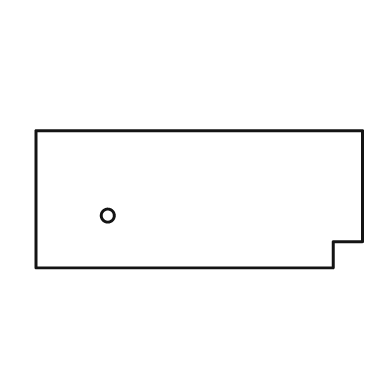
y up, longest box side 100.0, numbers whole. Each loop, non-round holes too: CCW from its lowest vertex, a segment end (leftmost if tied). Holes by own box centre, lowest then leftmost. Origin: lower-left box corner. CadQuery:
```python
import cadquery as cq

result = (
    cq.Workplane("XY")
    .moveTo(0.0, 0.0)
    .lineTo(91.0, 0.0)
    .lineTo(91.0, 8.0)
    .lineTo(100.0, 8.0)
    .lineTo(100.0, 42.0)
    .lineTo(0.0, 42.0)
    .close()
    .moveTo(22.0, 16.0)
    .circle(2.0)
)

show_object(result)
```